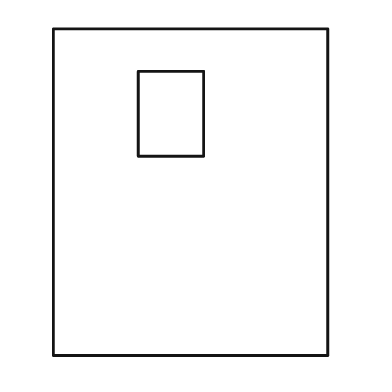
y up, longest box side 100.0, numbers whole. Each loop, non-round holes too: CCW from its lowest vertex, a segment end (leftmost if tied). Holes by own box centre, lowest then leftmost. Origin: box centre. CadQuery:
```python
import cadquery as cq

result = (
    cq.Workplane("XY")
    .moveTo(-42.0, -50.0)
    .lineTo(42.0, -50.0)
    .lineTo(42.0, 50.0)
    .lineTo(-42.0, 50.0)
    .close()
    .moveTo(-16.0, 11.0)
    .lineTo(4.0, 11.0)
    .lineTo(4.0, 37.0)
    .lineTo(-16.0, 37.0)
    .close()
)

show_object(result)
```